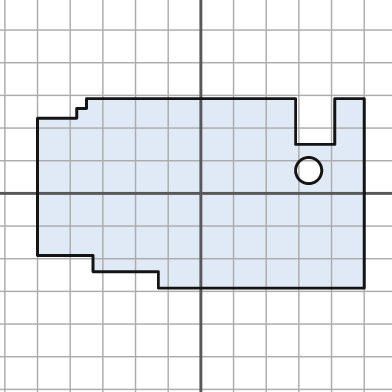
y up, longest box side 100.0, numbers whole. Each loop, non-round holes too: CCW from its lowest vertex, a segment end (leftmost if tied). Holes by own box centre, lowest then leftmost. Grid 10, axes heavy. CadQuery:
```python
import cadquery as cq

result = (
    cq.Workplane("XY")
    .moveTo(-13.0, -29.0)
    .lineTo(50.0, -29.0)
    .lineTo(50.0, 29.0)
    .lineTo(41.0, 29.0)
    .lineTo(41.0, 15.0)
    .lineTo(29.0, 15.0)
    .lineTo(29.0, 29.0)
    .lineTo(-35.0, 29.0)
    .lineTo(-35.0, 26.0)
    .lineTo(-38.0, 26.0)
    .lineTo(-38.0, 23.0)
    .lineTo(-50.0, 23.0)
    .lineTo(-50.0, -19.0)
    .lineTo(-33.0, -19.0)
    .lineTo(-33.0, -24.0)
    .lineTo(-13.0, -24.0)
    .close()
    .moveTo(33.0, 7.0)
    .circle(4.0)
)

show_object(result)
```